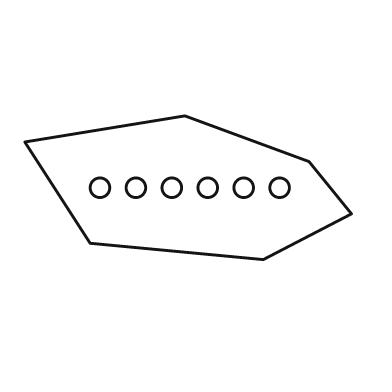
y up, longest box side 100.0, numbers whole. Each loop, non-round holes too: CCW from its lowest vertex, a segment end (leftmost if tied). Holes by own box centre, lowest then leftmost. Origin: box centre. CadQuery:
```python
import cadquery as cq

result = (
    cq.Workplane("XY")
    .moveTo(23.0, -22.0)
    .lineTo(50.0, -8.0)
    .lineTo(37.0, 8.0)
    .lineTo(-1.0, 22.0)
    .lineTo(-50.0, 14.0)
    .lineTo(-30.0, -17.0)
    .close()
    .moveTo(-27.0, 0.0)
    .circle(3.0)
    .moveTo(-16.0, 0.0)
    .circle(3.0)
    .moveTo(-5.0, 0.0)
    .circle(3.0)
    .moveTo(6.0, 0.0)
    .circle(3.0)
    .moveTo(17.0, 0.0)
    .circle(3.0)
    .moveTo(28.0, 0.0)
    .circle(3.0)
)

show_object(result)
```